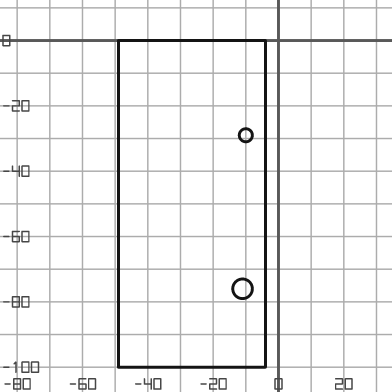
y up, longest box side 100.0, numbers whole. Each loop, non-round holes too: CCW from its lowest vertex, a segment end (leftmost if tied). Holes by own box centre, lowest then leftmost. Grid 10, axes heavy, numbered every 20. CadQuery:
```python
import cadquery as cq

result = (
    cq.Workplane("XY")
    .moveTo(-49.0, -100.0)
    .lineTo(-4.0, -100.0)
    .lineTo(-4.0, 0.0)
    .lineTo(-49.0, 0.0)
    .close()
    .moveTo(-11.0, -76.0)
    .circle(3.0)
    .moveTo(-10.0, -29.0)
    .circle(2.0)
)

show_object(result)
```